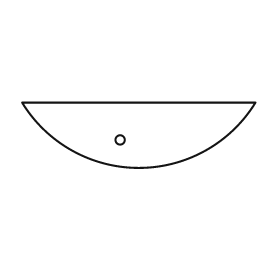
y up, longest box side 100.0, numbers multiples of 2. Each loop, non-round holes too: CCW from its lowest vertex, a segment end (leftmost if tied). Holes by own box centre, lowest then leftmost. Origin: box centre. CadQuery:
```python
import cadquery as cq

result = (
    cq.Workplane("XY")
    .moveTo(-50.0, 14.0)
    .threePointArc((0.0, -14.0), (50.0, 14.0))
    .close()
    .moveTo(-8.0, -2.0)
    .circle(2.0)
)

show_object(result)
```